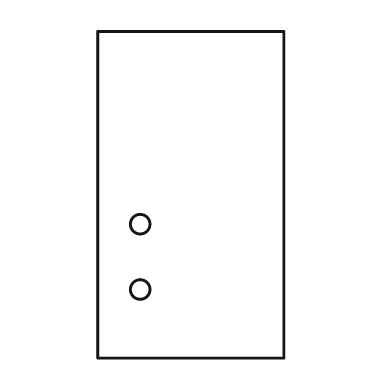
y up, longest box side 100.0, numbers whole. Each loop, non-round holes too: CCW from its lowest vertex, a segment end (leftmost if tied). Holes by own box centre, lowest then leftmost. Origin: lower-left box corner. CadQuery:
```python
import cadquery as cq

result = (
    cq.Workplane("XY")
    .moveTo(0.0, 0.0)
    .lineTo(57.0, 0.0)
    .lineTo(57.0, 100.0)
    .lineTo(0.0, 100.0)
    .close()
    .moveTo(13.0, 21.0)
    .circle(3.0)
    .moveTo(13.0, 41.0)
    .circle(3.0)
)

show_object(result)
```